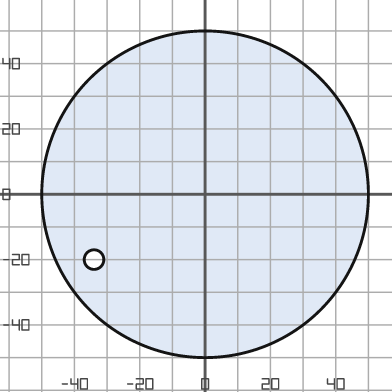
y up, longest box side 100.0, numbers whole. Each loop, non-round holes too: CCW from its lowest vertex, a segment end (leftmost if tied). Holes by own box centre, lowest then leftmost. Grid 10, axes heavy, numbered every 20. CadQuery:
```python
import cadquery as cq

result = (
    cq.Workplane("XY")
    .moveTo(0.0, 0.0)
    .circle(50.0)
    .moveTo(-34.0, -20.0)
    .circle(3.0)
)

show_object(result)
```